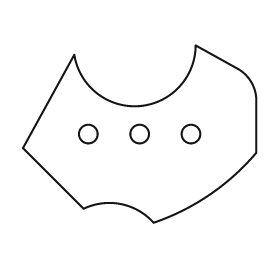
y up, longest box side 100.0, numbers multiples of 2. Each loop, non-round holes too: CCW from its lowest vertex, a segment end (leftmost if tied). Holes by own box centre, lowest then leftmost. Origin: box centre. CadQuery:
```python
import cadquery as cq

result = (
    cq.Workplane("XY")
    .moveTo(6.0, -38.0)
    .threePointArc((30.0, -26.0), (50.0, -8.0))
    .lineTo(50.0, 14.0)
    .threePointArc((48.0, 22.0), (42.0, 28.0))
    .lineTo(24.0, 38.0)
    .threePointArc((0.0, 12.0), (-28.0, 34.0))
    .lineTo(-50.0, -6.0)
    .lineTo(-24.0, -32.0)
    .threePointArc((-8.0, -30.0), (6.0, -38.0))
    .close()
    .moveTo(-22.0, 0.0)
    .circle(4.0)
    .moveTo(0.0, 0.0)
    .circle(4.0)
    .moveTo(22.0, 0.0)
    .circle(4.0)
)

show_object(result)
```